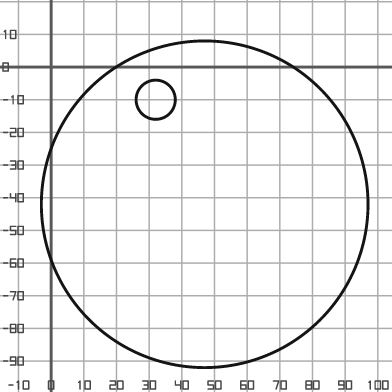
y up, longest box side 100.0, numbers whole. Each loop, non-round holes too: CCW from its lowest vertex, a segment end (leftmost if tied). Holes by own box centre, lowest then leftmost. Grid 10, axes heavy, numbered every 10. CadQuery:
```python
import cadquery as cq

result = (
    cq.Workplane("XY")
    .moveTo(47.0, -42.0)
    .circle(50.0)
    .moveTo(32.0, -10.0)
    .circle(6.0)
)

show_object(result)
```